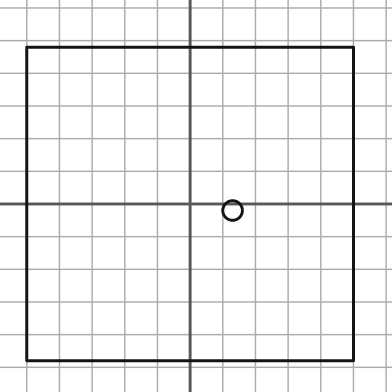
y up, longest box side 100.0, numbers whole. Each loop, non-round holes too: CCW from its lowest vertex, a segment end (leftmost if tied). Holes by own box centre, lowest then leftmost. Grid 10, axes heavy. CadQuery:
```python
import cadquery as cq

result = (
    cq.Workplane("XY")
    .moveTo(-50.0, -48.0)
    .lineTo(50.0, -48.0)
    .lineTo(50.0, 48.0)
    .lineTo(-50.0, 48.0)
    .close()
    .moveTo(13.0, -2.0)
    .circle(3.0)
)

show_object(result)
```